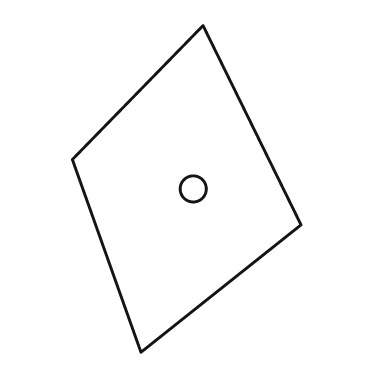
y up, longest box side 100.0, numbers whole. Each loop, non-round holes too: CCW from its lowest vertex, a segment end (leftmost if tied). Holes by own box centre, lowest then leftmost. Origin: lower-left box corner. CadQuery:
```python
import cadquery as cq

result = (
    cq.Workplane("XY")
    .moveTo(21.0, 0.0)
    .lineTo(70.0, 39.0)
    .lineTo(40.0, 100.0)
    .lineTo(0.0, 59.0)
    .close()
    .moveTo(37.0, 50.0)
    .circle(4.0)
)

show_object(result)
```